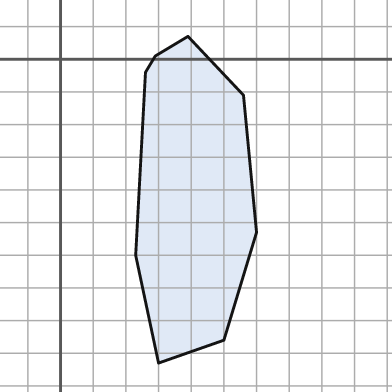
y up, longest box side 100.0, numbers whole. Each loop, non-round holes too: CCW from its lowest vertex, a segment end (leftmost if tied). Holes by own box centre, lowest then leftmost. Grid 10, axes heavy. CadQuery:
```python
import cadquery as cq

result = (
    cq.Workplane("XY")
    .moveTo(30.0, -93.0)
    .lineTo(50.0, -86.0)
    .lineTo(60.0, -53.0)
    .lineTo(56.0, -11.0)
    .lineTo(39.0, 7.0)
    .lineTo(29.0, 1.0)
    .lineTo(26.0, -4.0)
    .lineTo(23.0, -60.0)
    .close()
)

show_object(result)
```